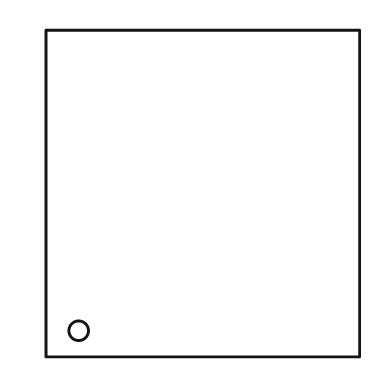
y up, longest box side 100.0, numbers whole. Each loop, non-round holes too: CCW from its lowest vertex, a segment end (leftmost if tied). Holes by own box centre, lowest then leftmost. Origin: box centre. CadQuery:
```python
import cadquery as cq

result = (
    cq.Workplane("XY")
    .moveTo(-48.0, -50.0)
    .lineTo(48.0, -50.0)
    .lineTo(48.0, 50.0)
    .lineTo(-48.0, 50.0)
    .close()
    .moveTo(-38.0, -42.0)
    .circle(3.0)
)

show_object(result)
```